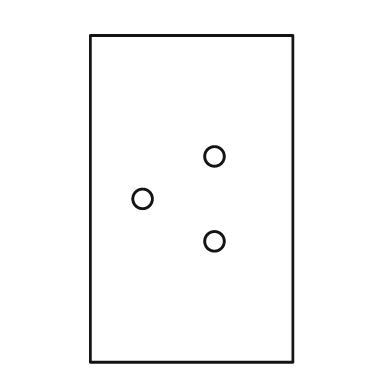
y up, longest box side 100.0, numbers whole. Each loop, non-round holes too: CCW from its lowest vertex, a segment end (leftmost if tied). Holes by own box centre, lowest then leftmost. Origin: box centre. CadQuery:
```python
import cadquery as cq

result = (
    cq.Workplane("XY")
    .moveTo(-31.0, -50.0)
    .lineTo(31.0, -50.0)
    .lineTo(31.0, 50.0)
    .lineTo(-31.0, 50.0)
    .close()
    .moveTo(7.0, -13.0)
    .circle(3.0)
    .moveTo(-15.0, 0.0)
    .circle(3.0)
    .moveTo(7.0, 13.0)
    .circle(3.0)
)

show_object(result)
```